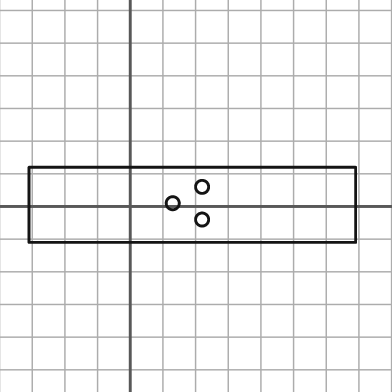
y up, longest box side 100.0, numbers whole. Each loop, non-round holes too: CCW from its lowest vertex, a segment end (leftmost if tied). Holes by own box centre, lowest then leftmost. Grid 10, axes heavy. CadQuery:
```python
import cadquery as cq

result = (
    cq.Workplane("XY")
    .moveTo(-31.0, -11.0)
    .lineTo(69.0, -11.0)
    .lineTo(69.0, 12.0)
    .lineTo(-31.0, 12.0)
    .close()
    .moveTo(22.0, -4.0)
    .circle(2.0)
    .moveTo(13.0, 1.0)
    .circle(2.0)
    .moveTo(22.0, 6.0)
    .circle(2.0)
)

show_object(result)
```